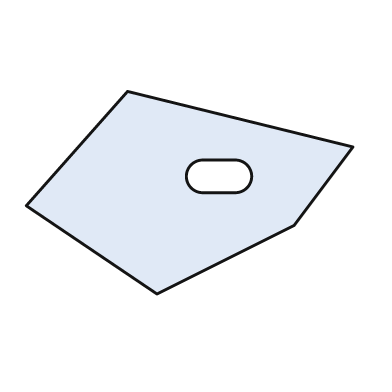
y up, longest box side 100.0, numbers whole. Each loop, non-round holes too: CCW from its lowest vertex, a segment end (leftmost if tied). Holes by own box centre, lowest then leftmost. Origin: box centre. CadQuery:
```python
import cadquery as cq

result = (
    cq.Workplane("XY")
    .moveTo(-10.0, -31.0)
    .lineTo(32.0, -10.0)
    .lineTo(50.0, 14.0)
    .lineTo(-19.0, 31.0)
    .lineTo(-50.0, -4.0)
    .close()
    .moveTo(4.0, 0.0)
    .lineTo(14.0, 0.0)
    .threePointArc((19.0, 5.0), (14.0, 10.0))
    .lineTo(4.0, 10.0)
    .threePointArc((-1.0, 5.0), (4.0, 0.0))
    .close()
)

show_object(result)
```